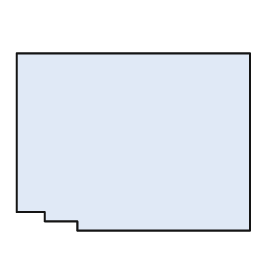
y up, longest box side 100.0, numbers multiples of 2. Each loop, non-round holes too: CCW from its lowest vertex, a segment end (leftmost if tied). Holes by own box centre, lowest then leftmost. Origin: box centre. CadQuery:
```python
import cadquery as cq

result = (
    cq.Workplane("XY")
    .moveTo(-24.0, -38.0)
    .lineTo(50.0, -38.0)
    .lineTo(50.0, 38.0)
    .lineTo(-50.0, 38.0)
    .lineTo(-50.0, -30.0)
    .lineTo(-38.0, -30.0)
    .lineTo(-38.0, -34.0)
    .lineTo(-24.0, -34.0)
    .close()
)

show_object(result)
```